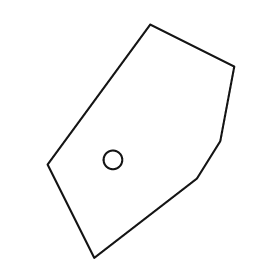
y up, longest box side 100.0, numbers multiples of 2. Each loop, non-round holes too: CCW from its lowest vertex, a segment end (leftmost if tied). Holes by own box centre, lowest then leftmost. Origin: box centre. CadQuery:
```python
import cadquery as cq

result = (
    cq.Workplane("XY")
    .moveTo(-20.0, -50.0)
    .lineTo(24.0, -16.0)
    .lineTo(34.0, 0.0)
    .lineTo(40.0, 32.0)
    .lineTo(4.0, 50.0)
    .lineTo(-40.0, -10.0)
    .close()
    .moveTo(-12.0, -8.0)
    .circle(4.0)
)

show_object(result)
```